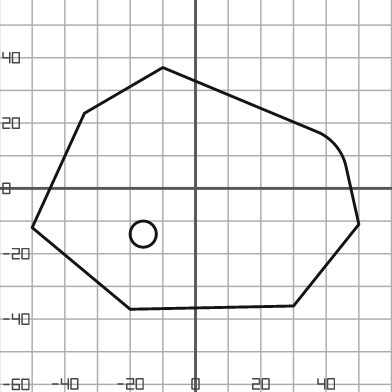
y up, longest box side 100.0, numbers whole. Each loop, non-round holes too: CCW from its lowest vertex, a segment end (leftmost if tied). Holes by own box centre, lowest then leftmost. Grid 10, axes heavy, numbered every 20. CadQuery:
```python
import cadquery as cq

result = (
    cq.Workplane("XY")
    .moveTo(-20.0, -37.0)
    .lineTo(30.0, -36.0)
    .lineTo(50.0, -11.0)
    .lineTo(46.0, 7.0)
    .threePointArc((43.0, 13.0), (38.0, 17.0))
    .lineTo(-10.0, 37.0)
    .lineTo(-34.0, 23.0)
    .lineTo(-50.0, -12.0)
    .close()
    .moveTo(-16.0, -14.0)
    .circle(4.0)
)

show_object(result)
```